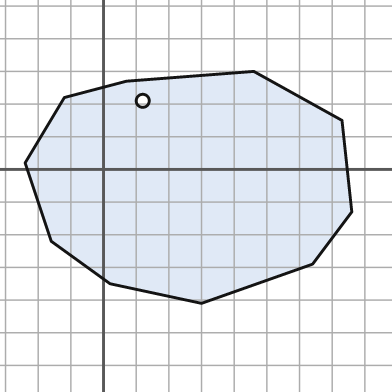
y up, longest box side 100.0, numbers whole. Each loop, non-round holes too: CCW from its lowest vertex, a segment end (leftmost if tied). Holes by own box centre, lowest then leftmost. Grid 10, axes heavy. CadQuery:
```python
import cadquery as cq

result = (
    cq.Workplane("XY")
    .moveTo(30.0, -41.0)
    .lineTo(64.0, -29.0)
    .lineTo(76.0, -13.0)
    .lineTo(73.0, 15.0)
    .lineTo(46.0, 30.0)
    .lineTo(7.0, 27.0)
    .lineTo(-12.0, 22.0)
    .lineTo(-24.0, 2.0)
    .lineTo(-16.0, -22.0)
    .lineTo(2.0, -35.0)
    .close()
    .moveTo(12.0, 21.0)
    .circle(2.0)
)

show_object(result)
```